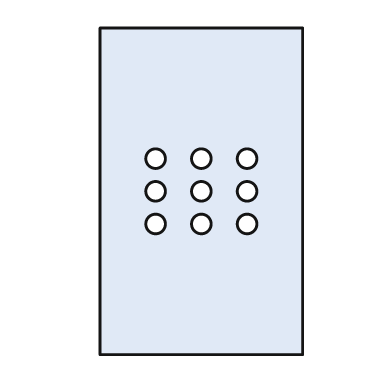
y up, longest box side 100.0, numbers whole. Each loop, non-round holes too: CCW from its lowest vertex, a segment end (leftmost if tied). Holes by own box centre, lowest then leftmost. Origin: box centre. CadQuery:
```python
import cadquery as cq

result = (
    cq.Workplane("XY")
    .moveTo(-31.0, -50.0)
    .lineTo(31.0, -50.0)
    .lineTo(31.0, 50.0)
    .lineTo(-31.0, 50.0)
    .close()
    .moveTo(-14.0, -10.0)
    .circle(3.0)
    .moveTo(0.0, -10.0)
    .circle(3.0)
    .moveTo(14.0, -10.0)
    .circle(3.0)
    .moveTo(-14.0, 0.0)
    .circle(3.0)
    .moveTo(0.0, 0.0)
    .circle(3.0)
    .moveTo(14.0, 0.0)
    .circle(3.0)
    .moveTo(-14.0, 10.0)
    .circle(3.0)
    .moveTo(0.0, 10.0)
    .circle(3.0)
    .moveTo(14.0, 10.0)
    .circle(3.0)
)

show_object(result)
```